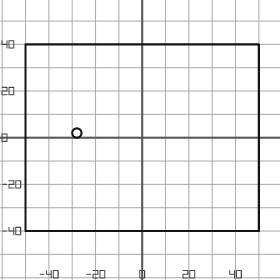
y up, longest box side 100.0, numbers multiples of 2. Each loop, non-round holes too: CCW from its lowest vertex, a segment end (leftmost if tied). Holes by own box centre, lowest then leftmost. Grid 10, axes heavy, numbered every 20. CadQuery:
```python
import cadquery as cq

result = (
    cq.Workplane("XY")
    .moveTo(-50.0, -40.0)
    .lineTo(50.0, -40.0)
    .lineTo(50.0, 40.0)
    .lineTo(-50.0, 40.0)
    .close()
    .moveTo(-28.0, 2.0)
    .circle(2.0)
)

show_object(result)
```